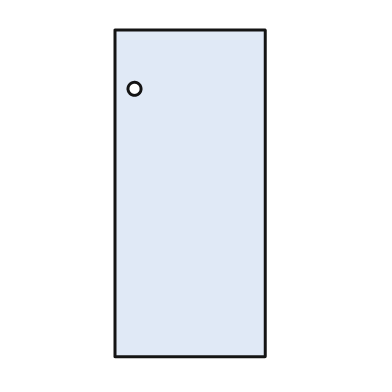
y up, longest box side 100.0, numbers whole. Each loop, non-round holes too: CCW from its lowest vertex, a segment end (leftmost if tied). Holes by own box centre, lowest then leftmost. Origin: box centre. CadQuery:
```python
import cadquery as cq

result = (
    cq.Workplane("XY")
    .moveTo(-23.0, -50.0)
    .lineTo(23.0, -50.0)
    .lineTo(23.0, 50.0)
    .lineTo(-23.0, 50.0)
    .close()
    .moveTo(-17.0, 32.0)
    .circle(2.0)
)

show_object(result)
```